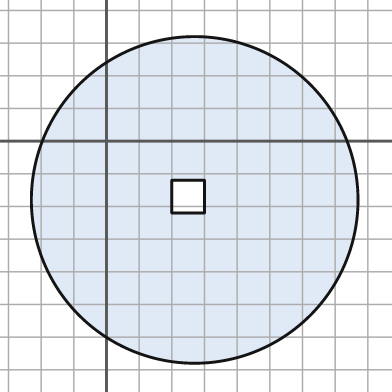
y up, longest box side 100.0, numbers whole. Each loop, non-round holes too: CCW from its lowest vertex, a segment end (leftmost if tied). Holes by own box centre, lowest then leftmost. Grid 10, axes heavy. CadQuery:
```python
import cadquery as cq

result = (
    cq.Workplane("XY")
    .moveTo(27.0, -18.0)
    .circle(50.0)
    .moveTo(20.0, -22.0)
    .lineTo(30.0, -22.0)
    .lineTo(30.0, -12.0)
    .lineTo(20.0, -12.0)
    .close()
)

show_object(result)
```